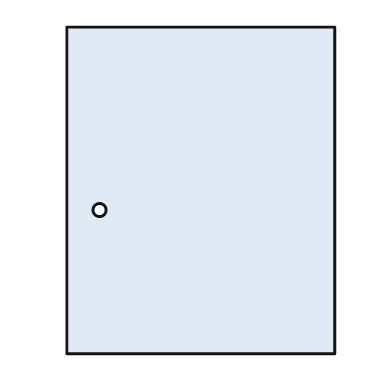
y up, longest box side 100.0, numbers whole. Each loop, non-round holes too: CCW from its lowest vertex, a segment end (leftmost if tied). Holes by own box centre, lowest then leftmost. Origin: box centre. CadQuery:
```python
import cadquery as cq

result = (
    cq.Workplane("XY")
    .moveTo(-41.0, -50.0)
    .lineTo(41.0, -50.0)
    .lineTo(41.0, 50.0)
    .lineTo(-41.0, 50.0)
    .close()
    .moveTo(-31.0, -6.0)
    .circle(2.0)
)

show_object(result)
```